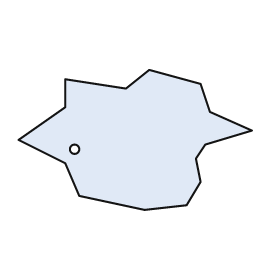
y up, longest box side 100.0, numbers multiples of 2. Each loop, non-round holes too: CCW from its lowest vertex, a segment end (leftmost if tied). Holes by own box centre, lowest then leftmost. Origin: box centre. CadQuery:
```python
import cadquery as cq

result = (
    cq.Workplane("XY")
    .moveTo(4.0, -30.0)
    .lineTo(22.0, -28.0)
    .lineTo(28.0, -18.0)
    .lineTo(26.0, -8.0)
    .lineTo(30.0, -2.0)
    .lineTo(50.0, 4.0)
    .lineTo(32.0, 12.0)
    .lineTo(28.0, 24.0)
    .lineTo(6.0, 30.0)
    .lineTo(-4.0, 22.0)
    .lineTo(-30.0, 26.0)
    .lineTo(-30.0, 14.0)
    .lineTo(-50.0, 0.0)
    .lineTo(-30.0, -10.0)
    .lineTo(-24.0, -24.0)
    .close()
    .moveTo(-26.0, -4.0)
    .circle(2.0)
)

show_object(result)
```